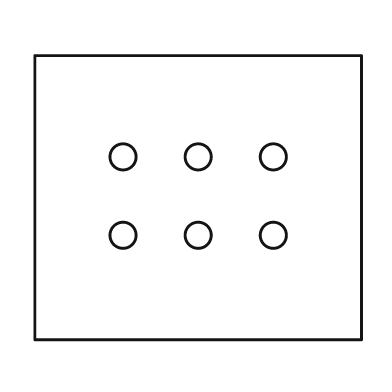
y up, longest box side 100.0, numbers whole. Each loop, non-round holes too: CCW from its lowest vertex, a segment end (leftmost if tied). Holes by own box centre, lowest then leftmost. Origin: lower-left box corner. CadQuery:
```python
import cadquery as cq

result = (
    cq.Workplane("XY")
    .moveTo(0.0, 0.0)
    .lineTo(100.0, 0.0)
    .lineTo(100.0, 87.0)
    .lineTo(0.0, 87.0)
    .close()
    .moveTo(27.0, 32.0)
    .circle(4.0)
    .moveTo(50.0, 32.0)
    .circle(4.0)
    .moveTo(73.0, 32.0)
    .circle(4.0)
    .moveTo(27.0, 56.0)
    .circle(4.0)
    .moveTo(50.0, 56.0)
    .circle(4.0)
    .moveTo(73.0, 56.0)
    .circle(4.0)
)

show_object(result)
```